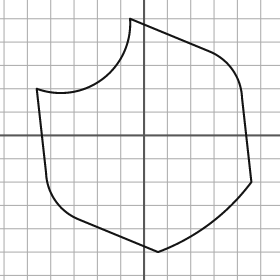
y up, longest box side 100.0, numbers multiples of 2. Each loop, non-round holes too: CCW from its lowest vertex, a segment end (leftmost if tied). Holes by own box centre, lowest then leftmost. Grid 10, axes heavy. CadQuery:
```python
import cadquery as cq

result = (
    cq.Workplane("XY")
    .moveTo(6.0, -50.0)
    .threePointArc((28.0, -38.0), (46.0, -20.0))
    .lineTo(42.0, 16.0)
    .threePointArc((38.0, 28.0), (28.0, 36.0))
    .lineTo(-6.0, 50.0)
    .threePointArc((-18.0, 24.0), (-46.0, 20.0))
    .lineTo(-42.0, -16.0)
    .threePointArc((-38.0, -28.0), (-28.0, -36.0))
    .close()
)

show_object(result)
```